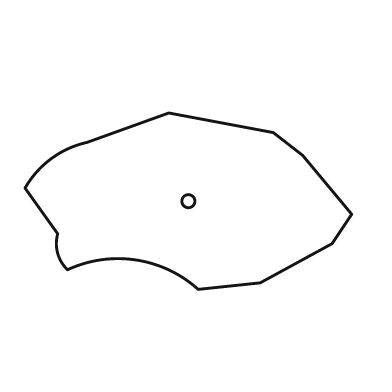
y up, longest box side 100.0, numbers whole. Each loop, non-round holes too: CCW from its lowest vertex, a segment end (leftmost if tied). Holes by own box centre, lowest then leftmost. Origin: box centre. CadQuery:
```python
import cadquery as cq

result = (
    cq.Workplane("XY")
    .moveTo(3.0, -27.0)
    .lineTo(22.0, -25.0)
    .lineTo(44.0, -13.0)
    .lineTo(50.0, -4.0)
    .lineTo(35.0, 14.0)
    .lineTo(26.0, 21.0)
    .lineTo(-6.0, 27.0)
    .lineTo(-31.0, 18.0)
    .threePointArc((-42.0, 13.0), (-50.0, 4.0))
    .lineTo(-40.0, -10.0)
    .threePointArc((-40.0, -16.0), (-37.0, -21.0))
    .threePointArc((-16.0, -18.0), (3.0, -27.0))
    .close()
    .moveTo(0.0, 0.0)
    .circle(2.0)
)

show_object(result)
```